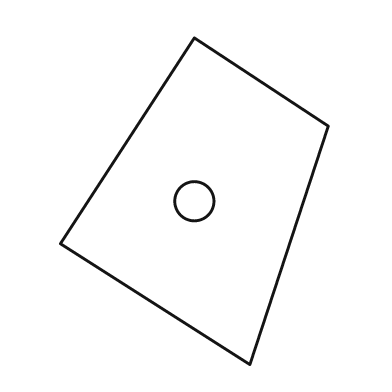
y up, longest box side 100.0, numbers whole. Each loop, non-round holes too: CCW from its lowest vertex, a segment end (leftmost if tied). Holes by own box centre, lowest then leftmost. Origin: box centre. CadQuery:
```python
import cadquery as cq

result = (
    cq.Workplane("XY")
    .moveTo(17.0, -50.0)
    .lineTo(41.0, 23.0)
    .lineTo(0.0, 50.0)
    .lineTo(-41.0, -13.0)
    .close()
    .moveTo(0.0, 0.0)
    .circle(6.0)
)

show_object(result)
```